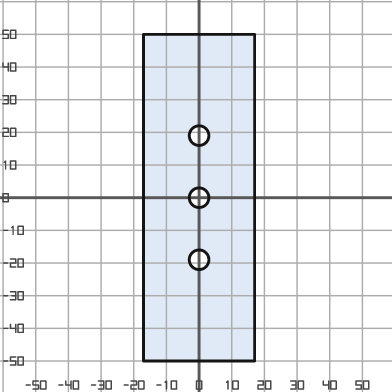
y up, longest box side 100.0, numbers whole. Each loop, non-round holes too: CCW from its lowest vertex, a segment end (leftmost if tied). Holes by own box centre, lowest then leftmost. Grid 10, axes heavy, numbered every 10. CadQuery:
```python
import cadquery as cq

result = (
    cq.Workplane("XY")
    .moveTo(-17.0, -50.0)
    .lineTo(17.0, -50.0)
    .lineTo(17.0, 50.0)
    .lineTo(-17.0, 50.0)
    .close()
    .moveTo(0.0, -19.0)
    .circle(3.0)
    .moveTo(0.0, 0.0)
    .circle(3.0)
    .moveTo(0.0, 19.0)
    .circle(3.0)
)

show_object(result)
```